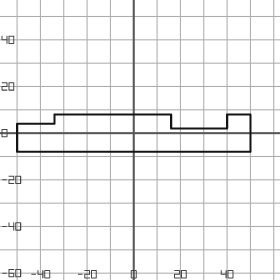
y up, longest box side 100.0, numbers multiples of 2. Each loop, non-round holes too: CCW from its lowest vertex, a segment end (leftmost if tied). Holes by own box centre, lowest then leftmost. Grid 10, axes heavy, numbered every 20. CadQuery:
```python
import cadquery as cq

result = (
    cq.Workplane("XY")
    .moveTo(-50.0, -8.0)
    .lineTo(50.0, -8.0)
    .lineTo(50.0, 8.0)
    .lineTo(40.0, 8.0)
    .lineTo(40.0, 2.0)
    .lineTo(16.0, 2.0)
    .lineTo(16.0, 8.0)
    .lineTo(-34.0, 8.0)
    .lineTo(-34.0, 4.0)
    .lineTo(-50.0, 4.0)
    .close()
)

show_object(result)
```